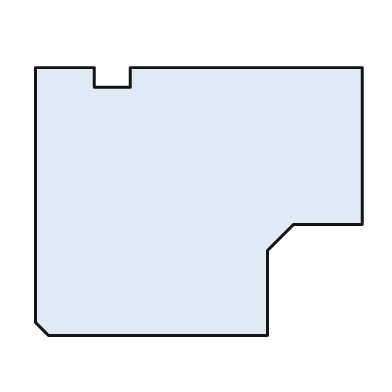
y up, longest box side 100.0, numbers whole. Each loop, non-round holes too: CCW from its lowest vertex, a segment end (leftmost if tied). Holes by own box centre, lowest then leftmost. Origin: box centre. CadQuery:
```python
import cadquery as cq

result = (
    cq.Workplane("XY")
    .moveTo(-46.0, -41.0)
    .lineTo(21.0, -41.0)
    .lineTo(21.0, -15.0)
    .lineTo(29.0, -7.0)
    .lineTo(50.0, -7.0)
    .lineTo(50.0, 41.0)
    .lineTo(-21.0, 41.0)
    .lineTo(-21.0, 35.0)
    .lineTo(-32.0, 35.0)
    .lineTo(-32.0, 41.0)
    .lineTo(-50.0, 41.0)
    .lineTo(-50.0, -37.0)
    .close()
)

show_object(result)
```